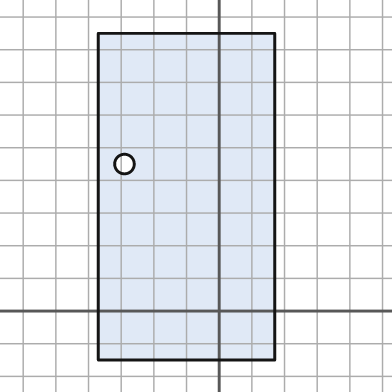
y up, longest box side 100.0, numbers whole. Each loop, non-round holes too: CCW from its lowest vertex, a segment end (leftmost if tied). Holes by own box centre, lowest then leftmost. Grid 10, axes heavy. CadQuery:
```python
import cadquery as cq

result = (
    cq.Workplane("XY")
    .moveTo(-37.0, -15.0)
    .lineTo(17.0, -15.0)
    .lineTo(17.0, 85.0)
    .lineTo(-37.0, 85.0)
    .close()
    .moveTo(-29.0, 45.0)
    .circle(3.0)
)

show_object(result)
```